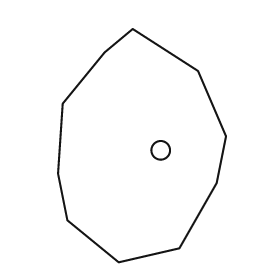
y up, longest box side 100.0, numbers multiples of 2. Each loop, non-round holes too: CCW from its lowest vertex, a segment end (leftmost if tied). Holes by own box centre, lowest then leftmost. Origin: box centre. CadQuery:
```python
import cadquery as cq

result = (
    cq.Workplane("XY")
    .moveTo(-10.0, -50.0)
    .lineTo(16.0, -44.0)
    .lineTo(32.0, -16.0)
    .lineTo(36.0, 4.0)
    .lineTo(24.0, 32.0)
    .lineTo(-4.0, 50.0)
    .lineTo(-16.0, 40.0)
    .lineTo(-34.0, 18.0)
    .lineTo(-36.0, -12.0)
    .lineTo(-32.0, -32.0)
    .close()
    .moveTo(8.0, -2.0)
    .circle(4.0)
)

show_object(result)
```